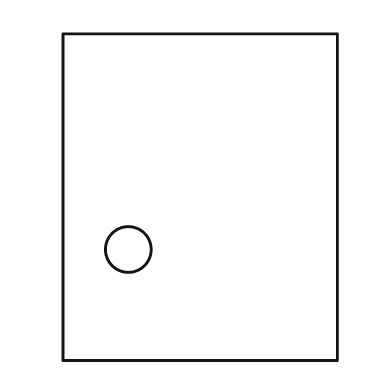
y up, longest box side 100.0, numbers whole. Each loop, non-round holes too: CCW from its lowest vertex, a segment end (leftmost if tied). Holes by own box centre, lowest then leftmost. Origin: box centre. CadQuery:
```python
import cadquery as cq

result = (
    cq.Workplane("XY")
    .moveTo(-42.0, -50.0)
    .lineTo(42.0, -50.0)
    .lineTo(42.0, 50.0)
    .lineTo(-42.0, 50.0)
    .close()
    .moveTo(-22.0, -16.0)
    .circle(7.0)
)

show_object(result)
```